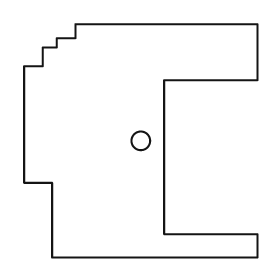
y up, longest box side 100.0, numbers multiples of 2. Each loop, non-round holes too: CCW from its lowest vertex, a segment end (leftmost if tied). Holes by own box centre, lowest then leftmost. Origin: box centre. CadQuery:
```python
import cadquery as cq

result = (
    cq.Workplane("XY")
    .moveTo(-38.0, -50.0)
    .lineTo(50.0, -50.0)
    .lineTo(50.0, -40.0)
    .lineTo(10.0, -40.0)
    .lineTo(10.0, 26.0)
    .lineTo(50.0, 26.0)
    .lineTo(50.0, 50.0)
    .lineTo(-28.0, 50.0)
    .lineTo(-28.0, 44.0)
    .lineTo(-36.0, 44.0)
    .lineTo(-36.0, 40.0)
    .lineTo(-42.0, 40.0)
    .lineTo(-42.0, 32.0)
    .lineTo(-50.0, 32.0)
    .lineTo(-50.0, -18.0)
    .lineTo(-38.0, -18.0)
    .close()
    .moveTo(0.0, 0.0)
    .circle(4.0)
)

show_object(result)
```